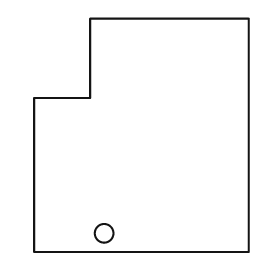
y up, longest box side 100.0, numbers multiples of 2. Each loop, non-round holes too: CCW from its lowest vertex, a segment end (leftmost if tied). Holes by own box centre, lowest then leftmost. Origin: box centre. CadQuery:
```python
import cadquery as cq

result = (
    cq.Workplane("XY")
    .moveTo(-46.0, -50.0)
    .lineTo(46.0, -50.0)
    .lineTo(46.0, 50.0)
    .lineTo(-22.0, 50.0)
    .lineTo(-22.0, 16.0)
    .lineTo(-46.0, 16.0)
    .close()
    .moveTo(-16.0, -42.0)
    .circle(4.0)
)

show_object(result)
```